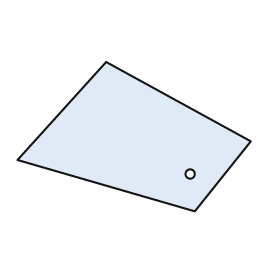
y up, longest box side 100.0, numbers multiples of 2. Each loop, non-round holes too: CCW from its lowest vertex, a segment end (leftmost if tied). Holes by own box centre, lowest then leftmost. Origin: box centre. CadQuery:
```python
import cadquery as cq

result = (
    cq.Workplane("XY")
    .moveTo(26.0, -32.0)
    .lineTo(50.0, -2.0)
    .lineTo(-12.0, 32.0)
    .lineTo(-50.0, -10.0)
    .close()
    .moveTo(24.0, -16.0)
    .circle(2.0)
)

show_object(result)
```